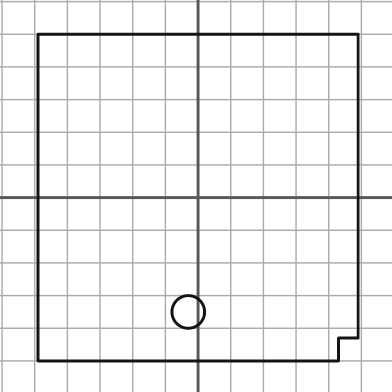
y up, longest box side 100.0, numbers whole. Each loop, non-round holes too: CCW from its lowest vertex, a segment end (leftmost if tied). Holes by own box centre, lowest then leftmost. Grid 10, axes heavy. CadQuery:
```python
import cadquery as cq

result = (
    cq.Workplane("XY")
    .moveTo(-49.0, -50.0)
    .lineTo(43.0, -50.0)
    .lineTo(43.0, -43.0)
    .lineTo(49.0, -43.0)
    .lineTo(49.0, 50.0)
    .lineTo(-49.0, 50.0)
    .close()
    .moveTo(-3.0, -35.0)
    .circle(5.0)
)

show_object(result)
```